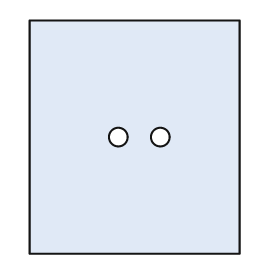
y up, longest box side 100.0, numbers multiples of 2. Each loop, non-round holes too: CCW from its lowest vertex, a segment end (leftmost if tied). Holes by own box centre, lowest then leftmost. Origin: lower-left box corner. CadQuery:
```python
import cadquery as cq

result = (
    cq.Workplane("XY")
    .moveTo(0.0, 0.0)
    .lineTo(90.0, 0.0)
    .lineTo(90.0, 100.0)
    .lineTo(0.0, 100.0)
    .close()
    .moveTo(38.0, 50.0)
    .circle(4.0)
    .moveTo(56.0, 50.0)
    .circle(4.0)
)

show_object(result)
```